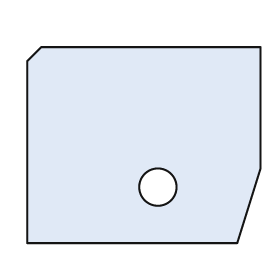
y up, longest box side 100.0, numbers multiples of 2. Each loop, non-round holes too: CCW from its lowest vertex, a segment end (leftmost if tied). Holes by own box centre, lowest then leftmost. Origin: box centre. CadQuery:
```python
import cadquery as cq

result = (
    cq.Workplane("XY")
    .moveTo(-50.0, -42.0)
    .lineTo(40.0, -42.0)
    .lineTo(50.0, -10.0)
    .lineTo(50.0, 42.0)
    .lineTo(-44.0, 42.0)
    .lineTo(-50.0, 36.0)
    .close()
    .moveTo(6.0, -18.0)
    .circle(8.0)
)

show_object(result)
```